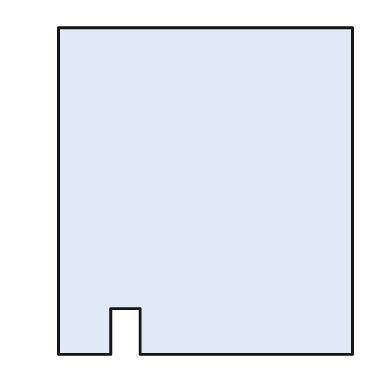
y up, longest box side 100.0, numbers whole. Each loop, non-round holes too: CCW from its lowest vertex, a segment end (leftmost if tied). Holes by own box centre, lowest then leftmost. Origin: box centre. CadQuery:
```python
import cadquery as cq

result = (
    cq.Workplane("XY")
    .moveTo(-45.0, -50.0)
    .lineTo(-29.0, -50.0)
    .lineTo(-29.0, -36.0)
    .lineTo(-20.0, -36.0)
    .lineTo(-20.0, -50.0)
    .lineTo(45.0, -50.0)
    .lineTo(45.0, 50.0)
    .lineTo(-45.0, 50.0)
    .close()
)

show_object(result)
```